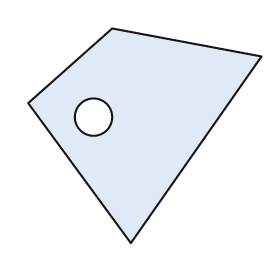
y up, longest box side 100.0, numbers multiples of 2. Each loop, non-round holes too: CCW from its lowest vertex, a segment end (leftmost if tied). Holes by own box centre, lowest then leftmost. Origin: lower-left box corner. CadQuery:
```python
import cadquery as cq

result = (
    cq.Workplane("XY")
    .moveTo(44.0, 0.0)
    .lineTo(100.0, 80.0)
    .lineTo(36.0, 92.0)
    .lineTo(0.0, 60.0)
    .close()
    .moveTo(28.0, 54.0)
    .circle(8.0)
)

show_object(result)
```